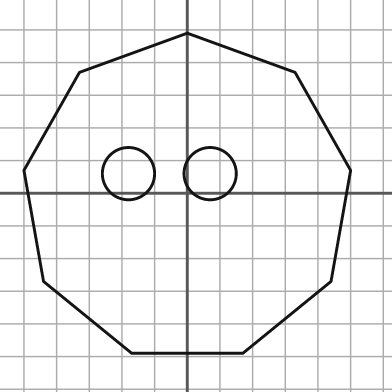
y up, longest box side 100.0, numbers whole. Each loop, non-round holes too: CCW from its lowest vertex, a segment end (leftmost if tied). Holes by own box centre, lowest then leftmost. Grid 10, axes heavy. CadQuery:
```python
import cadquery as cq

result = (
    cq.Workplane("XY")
    .moveTo(-17.0, -49.0)
    .lineTo(17.0, -49.0)
    .lineTo(44.0, -27.0)
    .lineTo(50.0, 7.0)
    .lineTo(33.0, 37.0)
    .lineTo(0.0, 49.0)
    .lineTo(-33.0, 37.0)
    .lineTo(-50.0, 7.0)
    .lineTo(-44.0, -27.0)
    .close()
    .moveTo(-18.0, 6.0)
    .circle(8.0)
    .moveTo(7.0, 6.0)
    .circle(8.0)
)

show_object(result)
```